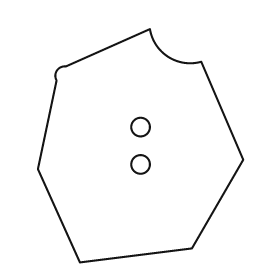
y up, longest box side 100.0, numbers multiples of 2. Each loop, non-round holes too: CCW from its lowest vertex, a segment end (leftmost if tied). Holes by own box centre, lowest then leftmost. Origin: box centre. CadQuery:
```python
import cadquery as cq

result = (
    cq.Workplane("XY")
    .moveTo(-26.0, -50.0)
    .lineTo(22.0, -44.0)
    .lineTo(44.0, -6.0)
    .lineTo(26.0, 36.0)
    .threePointArc((12.0, 38.0), (4.0, 50.0))
    .lineTo(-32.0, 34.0)
    .threePointArc((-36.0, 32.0), (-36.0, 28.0))
    .lineTo(-44.0, -10.0)
    .close()
    .moveTo(0.0, -8.0)
    .circle(4.0)
    .moveTo(0.0, 8.0)
    .circle(4.0)
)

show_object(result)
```